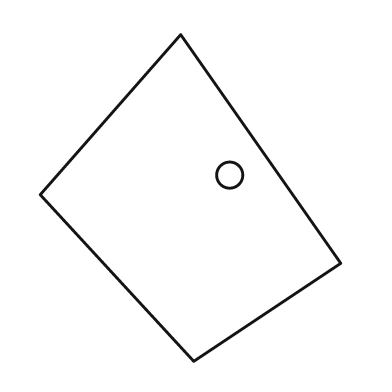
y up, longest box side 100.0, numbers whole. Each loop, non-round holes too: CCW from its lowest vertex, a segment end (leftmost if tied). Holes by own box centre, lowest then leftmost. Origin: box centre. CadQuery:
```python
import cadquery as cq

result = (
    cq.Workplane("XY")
    .moveTo(1.0, -50.0)
    .lineTo(46.0, -20.0)
    .lineTo(-3.0, 50.0)
    .lineTo(-46.0, 1.0)
    .close()
    .moveTo(12.0, 7.0)
    .circle(4.0)
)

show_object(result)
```